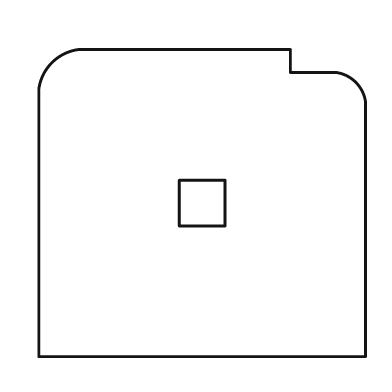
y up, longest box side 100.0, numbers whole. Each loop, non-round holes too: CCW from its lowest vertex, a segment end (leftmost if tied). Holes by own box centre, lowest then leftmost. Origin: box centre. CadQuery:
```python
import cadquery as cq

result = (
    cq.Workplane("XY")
    .moveTo(-50.0, -47.0)
    .lineTo(50.0, -47.0)
    .lineTo(50.0, 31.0)
    .threePointArc((47.0, 37.0), (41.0, 40.0))
    .lineTo(27.0, 40.0)
    .lineTo(27.0, 47.0)
    .lineTo(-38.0, 47.0)
    .threePointArc((-46.0, 43.0), (-50.0, 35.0))
    .close()
    .moveTo(-7.0, -7.0)
    .lineTo(7.0, -7.0)
    .lineTo(7.0, 7.0)
    .lineTo(-7.0, 7.0)
    .close()
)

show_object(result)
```